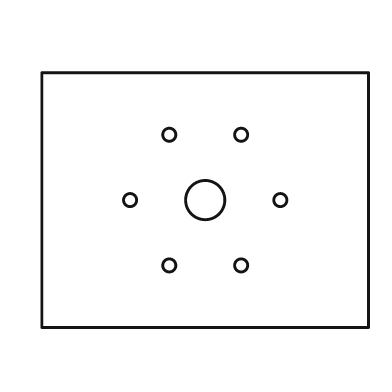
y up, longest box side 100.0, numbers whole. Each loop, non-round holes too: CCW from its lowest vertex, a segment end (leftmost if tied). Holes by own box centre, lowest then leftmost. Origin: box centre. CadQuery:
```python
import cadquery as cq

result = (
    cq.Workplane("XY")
    .moveTo(-50.0, -39.0)
    .lineTo(50.0, -39.0)
    .lineTo(50.0, 39.0)
    .lineTo(-50.0, 39.0)
    .close()
    .moveTo(-11.0, -20.0)
    .circle(2.0)
    .moveTo(11.0, -20.0)
    .circle(2.0)
    .moveTo(-23.0, 0.0)
    .circle(2.0)
    .moveTo(0.0, 0.0)
    .circle(6.0)
    .moveTo(23.0, 0.0)
    .circle(2.0)
    .moveTo(-11.0, 20.0)
    .circle(2.0)
    .moveTo(11.0, 20.0)
    .circle(2.0)
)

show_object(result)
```